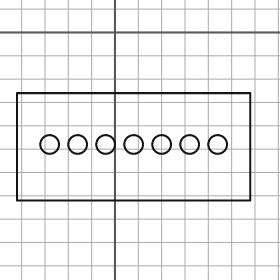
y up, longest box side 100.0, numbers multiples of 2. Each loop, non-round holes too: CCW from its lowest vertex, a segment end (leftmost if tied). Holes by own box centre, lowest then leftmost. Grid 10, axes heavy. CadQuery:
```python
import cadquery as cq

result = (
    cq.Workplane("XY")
    .moveTo(-42.0, -72.0)
    .lineTo(58.0, -72.0)
    .lineTo(58.0, -26.0)
    .lineTo(-42.0, -26.0)
    .close()
    .moveTo(-28.0, -48.0)
    .circle(4.0)
    .moveTo(-16.0, -48.0)
    .circle(4.0)
    .moveTo(-4.0, -48.0)
    .circle(4.0)
    .moveTo(8.0, -48.0)
    .circle(4.0)
    .moveTo(20.0, -48.0)
    .circle(4.0)
    .moveTo(32.0, -48.0)
    .circle(4.0)
    .moveTo(44.0, -48.0)
    .circle(4.0)
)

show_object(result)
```